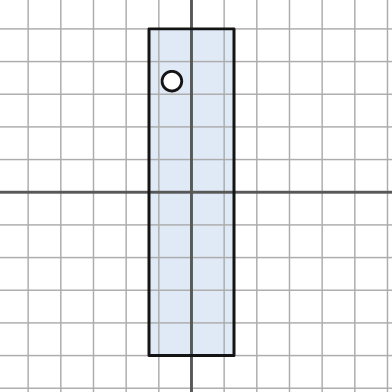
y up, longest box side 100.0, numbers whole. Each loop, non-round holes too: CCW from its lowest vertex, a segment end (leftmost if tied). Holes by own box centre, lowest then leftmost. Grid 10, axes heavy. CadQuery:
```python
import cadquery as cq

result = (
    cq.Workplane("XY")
    .moveTo(-13.0, -50.0)
    .lineTo(13.0, -50.0)
    .lineTo(13.0, 50.0)
    .lineTo(-13.0, 50.0)
    .close()
    .moveTo(-6.0, 34.0)
    .circle(3.0)
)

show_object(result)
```